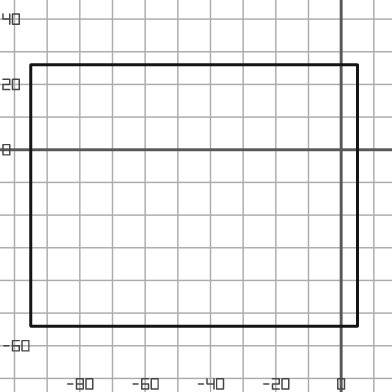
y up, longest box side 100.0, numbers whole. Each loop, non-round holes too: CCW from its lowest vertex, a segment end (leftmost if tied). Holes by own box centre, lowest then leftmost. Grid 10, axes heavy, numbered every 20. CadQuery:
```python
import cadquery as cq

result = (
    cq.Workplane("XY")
    .moveTo(-95.0, -54.0)
    .lineTo(5.0, -54.0)
    .lineTo(5.0, 26.0)
    .lineTo(-95.0, 26.0)
    .close()
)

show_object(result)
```